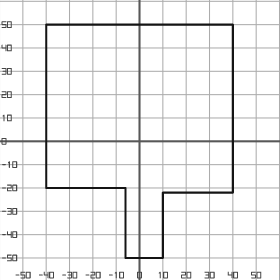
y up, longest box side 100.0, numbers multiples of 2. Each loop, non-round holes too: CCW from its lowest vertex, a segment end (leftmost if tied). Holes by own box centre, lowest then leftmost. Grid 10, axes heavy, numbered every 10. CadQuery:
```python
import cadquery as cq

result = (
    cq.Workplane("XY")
    .moveTo(-6.0, -50.0)
    .lineTo(10.0, -50.0)
    .lineTo(10.0, -22.0)
    .lineTo(40.0, -22.0)
    .lineTo(40.0, 50.0)
    .lineTo(-40.0, 50.0)
    .lineTo(-40.0, -20.0)
    .lineTo(-6.0, -20.0)
    .close()
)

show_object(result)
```